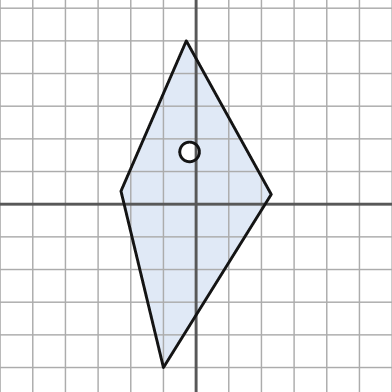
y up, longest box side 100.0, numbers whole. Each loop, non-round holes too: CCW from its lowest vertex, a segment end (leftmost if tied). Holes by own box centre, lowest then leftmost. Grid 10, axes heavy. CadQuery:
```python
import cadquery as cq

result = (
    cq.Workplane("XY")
    .moveTo(-10.0, -50.0)
    .lineTo(23.0, 3.0)
    .lineTo(-3.0, 50.0)
    .lineTo(-23.0, 4.0)
    .close()
    .moveTo(-2.0, 16.0)
    .circle(3.0)
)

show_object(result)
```